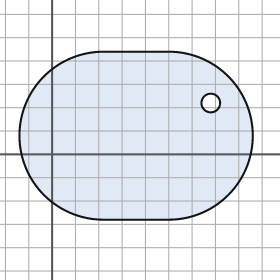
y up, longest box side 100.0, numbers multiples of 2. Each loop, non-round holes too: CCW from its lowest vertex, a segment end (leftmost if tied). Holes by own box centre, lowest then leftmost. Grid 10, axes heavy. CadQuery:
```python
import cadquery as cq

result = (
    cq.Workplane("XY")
    .moveTo(22.0, -28.0)
    .lineTo(50.0, -28.0)
    .threePointArc((86.0, 8.0), (50.0, 44.0))
    .lineTo(22.0, 44.0)
    .threePointArc((-14.0, 8.0), (22.0, -28.0))
    .close()
    .moveTo(68.0, 22.0)
    .circle(4.0)
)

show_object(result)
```